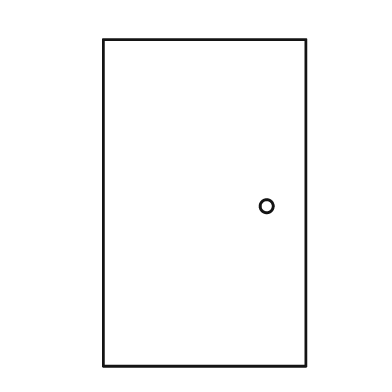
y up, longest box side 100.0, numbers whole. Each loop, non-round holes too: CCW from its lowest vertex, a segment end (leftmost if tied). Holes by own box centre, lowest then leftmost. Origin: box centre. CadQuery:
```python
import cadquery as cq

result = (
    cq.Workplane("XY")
    .moveTo(-31.0, -50.0)
    .lineTo(31.0, -50.0)
    .lineTo(31.0, 50.0)
    .lineTo(-31.0, 50.0)
    .close()
    .moveTo(19.0, -1.0)
    .circle(2.0)
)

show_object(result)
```